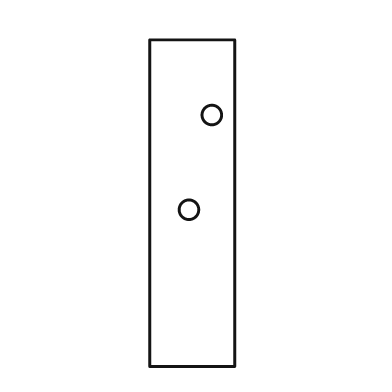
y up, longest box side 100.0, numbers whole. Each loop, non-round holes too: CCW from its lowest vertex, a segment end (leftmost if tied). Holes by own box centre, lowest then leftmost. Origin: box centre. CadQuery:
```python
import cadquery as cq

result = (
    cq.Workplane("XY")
    .moveTo(-13.0, -50.0)
    .lineTo(13.0, -50.0)
    .lineTo(13.0, 50.0)
    .lineTo(-13.0, 50.0)
    .close()
    .moveTo(-1.0, -2.0)
    .circle(3.0)
    .moveTo(6.0, 27.0)
    .circle(3.0)
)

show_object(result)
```